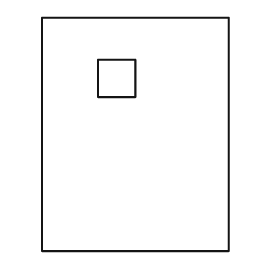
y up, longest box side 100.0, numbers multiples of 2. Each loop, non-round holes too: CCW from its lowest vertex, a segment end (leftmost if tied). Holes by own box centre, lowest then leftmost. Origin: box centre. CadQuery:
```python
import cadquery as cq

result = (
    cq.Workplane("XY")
    .moveTo(-40.0, -50.0)
    .lineTo(40.0, -50.0)
    .lineTo(40.0, 50.0)
    .lineTo(-40.0, 50.0)
    .close()
    .moveTo(-16.0, 16.0)
    .lineTo(0.0, 16.0)
    .lineTo(0.0, 32.0)
    .lineTo(-16.0, 32.0)
    .close()
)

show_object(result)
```